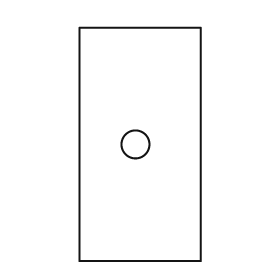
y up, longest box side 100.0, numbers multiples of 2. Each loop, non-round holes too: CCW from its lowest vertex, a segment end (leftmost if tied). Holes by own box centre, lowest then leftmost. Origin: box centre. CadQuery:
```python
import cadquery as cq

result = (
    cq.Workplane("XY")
    .moveTo(-26.0, -50.0)
    .lineTo(26.0, -50.0)
    .lineTo(26.0, 50.0)
    .lineTo(-26.0, 50.0)
    .close()
    .moveTo(-2.0, 0.0)
    .circle(6.0)
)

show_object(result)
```